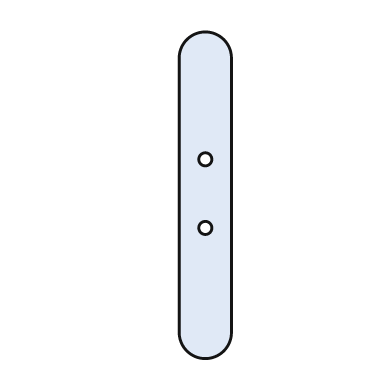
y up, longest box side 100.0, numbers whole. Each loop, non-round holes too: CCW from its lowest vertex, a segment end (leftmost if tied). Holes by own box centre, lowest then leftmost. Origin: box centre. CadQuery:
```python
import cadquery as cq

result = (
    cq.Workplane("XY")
    .moveTo(-8.0, -42.0)
    .threePointArc((0.0, -50.0), (8.0, -42.0))
    .lineTo(8.0, 42.0)
    .threePointArc((0.0, 50.0), (-8.0, 42.0))
    .close()
    .moveTo(0.0, -10.0)
    .circle(2.0)
    .moveTo(0.0, 11.0)
    .circle(2.0)
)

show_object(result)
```